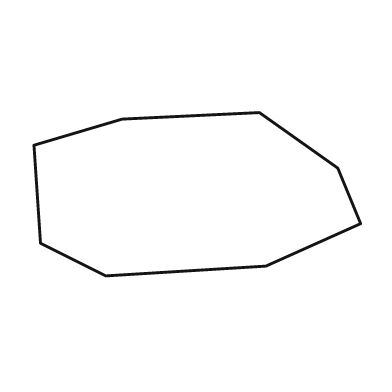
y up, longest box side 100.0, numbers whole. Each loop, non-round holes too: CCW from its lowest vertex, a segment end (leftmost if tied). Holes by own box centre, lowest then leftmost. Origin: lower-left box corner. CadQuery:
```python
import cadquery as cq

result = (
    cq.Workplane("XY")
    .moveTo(22.0, 0.0)
    .lineTo(71.0, 3.0)
    .lineTo(100.0, 16.0)
    .lineTo(93.0, 33.0)
    .lineTo(69.0, 50.0)
    .lineTo(27.0, 48.0)
    .lineTo(0.0, 40.0)
    .lineTo(2.0, 10.0)
    .close()
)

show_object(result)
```